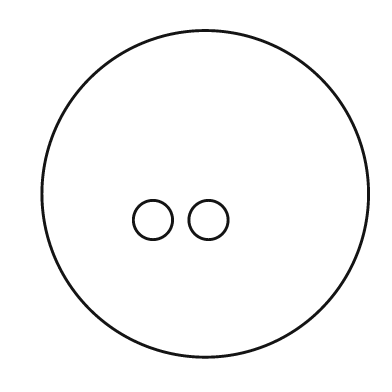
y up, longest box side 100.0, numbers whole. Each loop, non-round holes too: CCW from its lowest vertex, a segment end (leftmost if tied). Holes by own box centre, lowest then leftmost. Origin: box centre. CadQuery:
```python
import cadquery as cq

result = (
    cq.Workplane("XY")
    .moveTo(0.0, 0.0)
    .circle(50.0)
    .moveTo(-16.0, -8.0)
    .circle(6.0)
    .moveTo(1.0, -8.0)
    .circle(6.0)
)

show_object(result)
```